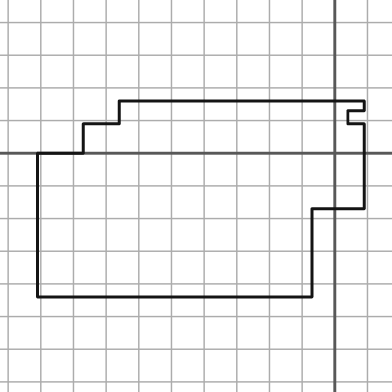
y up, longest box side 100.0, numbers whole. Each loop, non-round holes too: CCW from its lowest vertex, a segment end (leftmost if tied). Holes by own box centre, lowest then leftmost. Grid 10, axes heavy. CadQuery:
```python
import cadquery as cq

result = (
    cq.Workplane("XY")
    .moveTo(-91.0, -44.0)
    .lineTo(-7.0, -44.0)
    .lineTo(-7.0, -17.0)
    .lineTo(9.0, -17.0)
    .lineTo(9.0, 9.0)
    .lineTo(4.0, 9.0)
    .lineTo(4.0, 13.0)
    .lineTo(9.0, 13.0)
    .lineTo(9.0, 16.0)
    .lineTo(-66.0, 16.0)
    .lineTo(-66.0, 9.0)
    .lineTo(-77.0, 9.0)
    .lineTo(-77.0, 0.0)
    .lineTo(-91.0, 0.0)
    .close()
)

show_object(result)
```